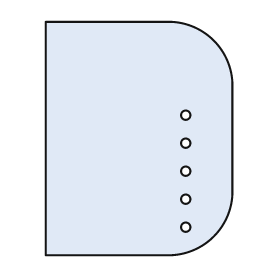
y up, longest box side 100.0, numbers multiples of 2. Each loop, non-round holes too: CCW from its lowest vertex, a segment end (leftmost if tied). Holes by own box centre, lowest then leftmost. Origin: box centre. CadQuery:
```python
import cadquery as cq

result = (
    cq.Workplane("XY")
    .moveTo(-40.0, -50.0)
    .lineTo(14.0, -50.0)
    .threePointArc((32.0, -42.0), (40.0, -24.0))
    .lineTo(40.0, 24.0)
    .threePointArc((32.0, 42.0), (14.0, 50.0))
    .lineTo(-40.0, 50.0)
    .close()
    .moveTo(20.0, -38.0)
    .circle(2.0)
    .moveTo(20.0, -26.0)
    .circle(2.0)
    .moveTo(20.0, -14.0)
    .circle(2.0)
    .moveTo(20.0, -2.0)
    .circle(2.0)
    .moveTo(20.0, 10.0)
    .circle(2.0)
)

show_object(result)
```